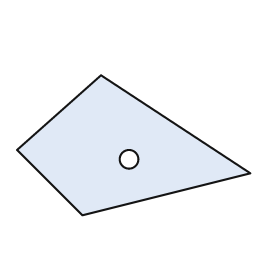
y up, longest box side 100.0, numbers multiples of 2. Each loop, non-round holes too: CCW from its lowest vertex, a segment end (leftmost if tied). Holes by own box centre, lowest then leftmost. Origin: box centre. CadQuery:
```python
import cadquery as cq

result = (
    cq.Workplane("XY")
    .moveTo(-22.0, -30.0)
    .lineTo(50.0, -12.0)
    .lineTo(-14.0, 30.0)
    .lineTo(-50.0, -2.0)
    .close()
    .moveTo(-2.0, -6.0)
    .circle(4.0)
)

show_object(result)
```